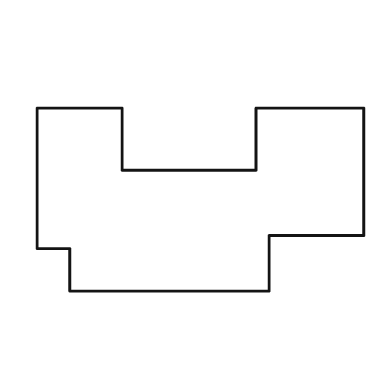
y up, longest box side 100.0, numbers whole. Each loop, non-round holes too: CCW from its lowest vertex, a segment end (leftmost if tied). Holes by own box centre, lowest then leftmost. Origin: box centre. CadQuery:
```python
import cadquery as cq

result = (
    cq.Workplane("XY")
    .moveTo(-40.0, -28.0)
    .lineTo(21.0, -28.0)
    .lineTo(21.0, -11.0)
    .lineTo(50.0, -11.0)
    .lineTo(50.0, 28.0)
    .lineTo(17.0, 28.0)
    .lineTo(17.0, 9.0)
    .lineTo(-24.0, 9.0)
    .lineTo(-24.0, 28.0)
    .lineTo(-50.0, 28.0)
    .lineTo(-50.0, -15.0)
    .lineTo(-40.0, -15.0)
    .close()
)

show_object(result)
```